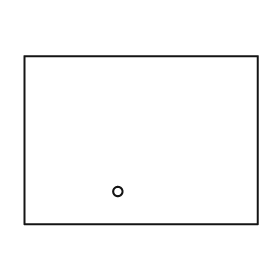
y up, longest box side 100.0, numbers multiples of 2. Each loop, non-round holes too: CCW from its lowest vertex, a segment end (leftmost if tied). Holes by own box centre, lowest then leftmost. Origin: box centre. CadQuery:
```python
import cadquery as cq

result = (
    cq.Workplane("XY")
    .moveTo(-50.0, -36.0)
    .lineTo(50.0, -36.0)
    .lineTo(50.0, 36.0)
    .lineTo(-50.0, 36.0)
    .close()
    .moveTo(-10.0, -22.0)
    .circle(2.0)
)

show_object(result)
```